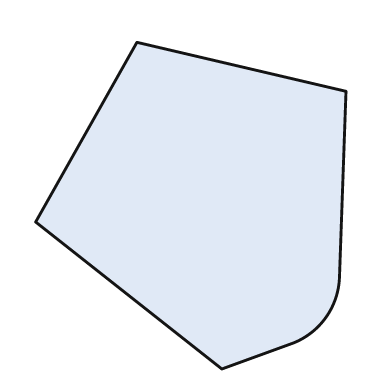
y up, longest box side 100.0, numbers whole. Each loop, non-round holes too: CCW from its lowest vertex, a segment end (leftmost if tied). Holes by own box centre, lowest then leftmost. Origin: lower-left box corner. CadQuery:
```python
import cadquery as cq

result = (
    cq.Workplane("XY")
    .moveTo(57.0, 0.0)
    .lineTo(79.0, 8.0)
    .threePointArc((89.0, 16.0), (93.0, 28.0))
    .lineTo(95.0, 85.0)
    .lineTo(31.0, 100.0)
    .lineTo(0.0, 45.0)
    .close()
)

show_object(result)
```